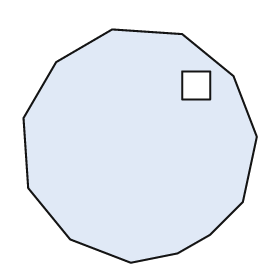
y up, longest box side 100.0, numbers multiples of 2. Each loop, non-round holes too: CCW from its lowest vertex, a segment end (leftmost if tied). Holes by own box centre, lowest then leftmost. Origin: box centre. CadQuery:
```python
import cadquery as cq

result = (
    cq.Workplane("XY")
    .moveTo(-4.0, -50.0)
    .lineTo(16.0, -46.0)
    .lineTo(30.0, -38.0)
    .lineTo(44.0, -24.0)
    .lineTo(50.0, 4.0)
    .lineTo(40.0, 30.0)
    .lineTo(18.0, 48.0)
    .lineTo(-12.0, 50.0)
    .lineTo(-36.0, 36.0)
    .lineTo(-50.0, 12.0)
    .lineTo(-48.0, -18.0)
    .lineTo(-30.0, -40.0)
    .close()
    .moveTo(18.0, 20.0)
    .lineTo(30.0, 20.0)
    .lineTo(30.0, 32.0)
    .lineTo(18.0, 32.0)
    .close()
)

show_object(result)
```